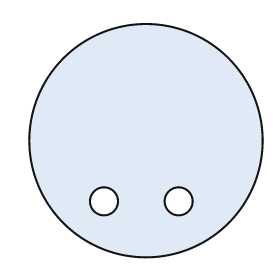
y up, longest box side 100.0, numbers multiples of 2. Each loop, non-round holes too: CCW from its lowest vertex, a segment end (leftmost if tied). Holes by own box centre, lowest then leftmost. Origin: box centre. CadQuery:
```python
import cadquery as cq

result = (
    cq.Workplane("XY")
    .moveTo(0.0, 0.0)
    .circle(50.0)
    .moveTo(-18.0, -26.0)
    .circle(6.0)
    .moveTo(14.0, -26.0)
    .circle(6.0)
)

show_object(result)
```